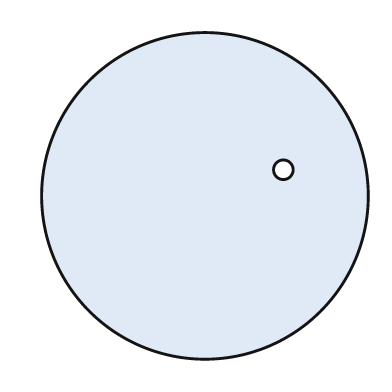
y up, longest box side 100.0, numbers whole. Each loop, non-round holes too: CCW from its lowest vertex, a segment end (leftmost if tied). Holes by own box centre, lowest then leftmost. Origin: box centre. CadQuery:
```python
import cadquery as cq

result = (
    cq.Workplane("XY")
    .moveTo(0.0, 0.0)
    .circle(50.0)
    .moveTo(24.0, 8.0)
    .circle(3.0)
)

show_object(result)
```